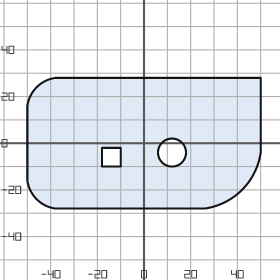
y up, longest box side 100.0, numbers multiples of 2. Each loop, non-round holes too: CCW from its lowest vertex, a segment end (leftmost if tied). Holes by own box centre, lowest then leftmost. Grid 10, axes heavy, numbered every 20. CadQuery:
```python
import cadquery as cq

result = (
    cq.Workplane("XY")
    .moveTo(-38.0, -28.0)
    .lineTo(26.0, -28.0)
    .threePointArc((42.0, -20.0), (50.0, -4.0))
    .lineTo(50.0, 28.0)
    .lineTo(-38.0, 28.0)
    .threePointArc((-46.0, 24.0), (-50.0, 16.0))
    .lineTo(-50.0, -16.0)
    .threePointArc((-46.0, -24.0), (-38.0, -28.0))
    .close()
    .moveTo(-18.0, -10.0)
    .lineTo(-10.0, -10.0)
    .lineTo(-10.0, -2.0)
    .lineTo(-18.0, -2.0)
    .close()
    .moveTo(12.0, -4.0)
    .circle(6.0)
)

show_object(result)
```